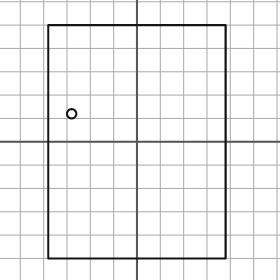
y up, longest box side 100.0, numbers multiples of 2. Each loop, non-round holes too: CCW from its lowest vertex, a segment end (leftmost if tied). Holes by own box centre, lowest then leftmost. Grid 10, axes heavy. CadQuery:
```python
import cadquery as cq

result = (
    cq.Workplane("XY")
    .moveTo(-38.0, -50.0)
    .lineTo(38.0, -50.0)
    .lineTo(38.0, 50.0)
    .lineTo(-38.0, 50.0)
    .close()
    .moveTo(-28.0, 12.0)
    .circle(2.0)
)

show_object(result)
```